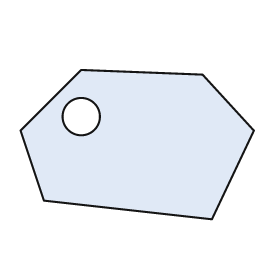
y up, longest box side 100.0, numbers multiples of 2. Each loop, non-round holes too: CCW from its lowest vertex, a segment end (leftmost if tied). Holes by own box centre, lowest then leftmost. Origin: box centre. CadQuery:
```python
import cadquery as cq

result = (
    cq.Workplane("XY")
    .moveTo(32.0, -32.0)
    .lineTo(50.0, 6.0)
    .lineTo(28.0, 30.0)
    .lineTo(-24.0, 32.0)
    .lineTo(-50.0, 6.0)
    .lineTo(-40.0, -24.0)
    .close()
    .moveTo(-24.0, 12.0)
    .circle(8.0)
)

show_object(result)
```